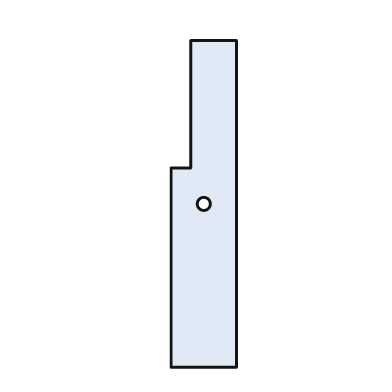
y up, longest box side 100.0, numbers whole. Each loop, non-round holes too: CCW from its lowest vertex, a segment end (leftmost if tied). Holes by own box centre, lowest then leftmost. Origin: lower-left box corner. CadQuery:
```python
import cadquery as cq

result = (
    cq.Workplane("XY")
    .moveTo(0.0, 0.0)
    .lineTo(20.0, 0.0)
    .lineTo(20.0, 100.0)
    .lineTo(6.0, 100.0)
    .lineTo(6.0, 61.0)
    .lineTo(0.0, 61.0)
    .close()
    .moveTo(10.0, 50.0)
    .circle(2.0)
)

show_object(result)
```